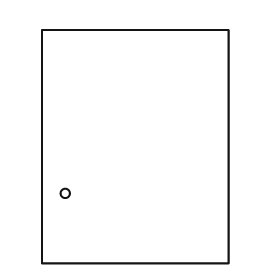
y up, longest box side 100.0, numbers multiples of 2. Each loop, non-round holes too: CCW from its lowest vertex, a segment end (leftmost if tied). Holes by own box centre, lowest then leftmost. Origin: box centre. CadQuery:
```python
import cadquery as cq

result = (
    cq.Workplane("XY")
    .moveTo(-40.0, -50.0)
    .lineTo(40.0, -50.0)
    .lineTo(40.0, 50.0)
    .lineTo(-40.0, 50.0)
    .close()
    .moveTo(-30.0, -20.0)
    .circle(2.0)
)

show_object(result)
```